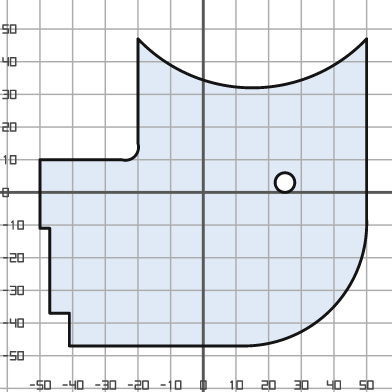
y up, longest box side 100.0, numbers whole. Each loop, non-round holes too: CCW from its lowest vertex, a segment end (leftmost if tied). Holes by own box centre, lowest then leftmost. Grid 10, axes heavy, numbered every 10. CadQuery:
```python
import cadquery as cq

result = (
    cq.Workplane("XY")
    .moveTo(-41.0, -47.0)
    .lineTo(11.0, -47.0)
    .threePointArc((39.0, -36.0), (50.0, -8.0))
    .lineTo(50.0, 47.0)
    .threePointArc((15.0, 32.0), (-20.0, 47.0))
    .lineTo(-20.0, 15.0)
    .threePointArc((-21.0, 11.0), (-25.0, 10.0))
    .lineTo(-50.0, 10.0)
    .lineTo(-50.0, -11.0)
    .lineTo(-47.0, -11.0)
    .lineTo(-47.0, -37.0)
    .lineTo(-41.0, -37.0)
    .close()
    .moveTo(25.0, 3.0)
    .circle(3.0)
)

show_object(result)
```